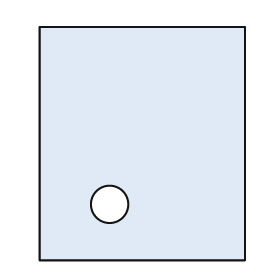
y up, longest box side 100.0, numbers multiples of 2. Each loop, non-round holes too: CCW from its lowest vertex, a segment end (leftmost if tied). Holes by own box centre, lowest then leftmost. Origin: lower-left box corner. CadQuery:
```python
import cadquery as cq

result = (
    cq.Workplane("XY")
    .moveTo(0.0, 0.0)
    .lineTo(88.0, 0.0)
    .lineTo(88.0, 100.0)
    .lineTo(0.0, 100.0)
    .close()
    .moveTo(30.0, 24.0)
    .circle(8.0)
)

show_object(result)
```